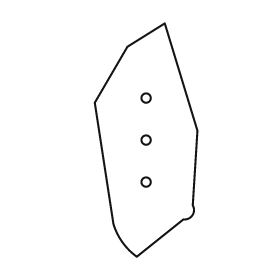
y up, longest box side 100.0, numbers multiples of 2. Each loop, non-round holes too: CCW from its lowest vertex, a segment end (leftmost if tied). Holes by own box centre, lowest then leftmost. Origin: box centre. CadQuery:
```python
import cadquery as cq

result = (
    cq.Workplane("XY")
    .moveTo(-4.0, -50.0)
    .lineTo(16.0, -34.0)
    .threePointArc((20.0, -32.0), (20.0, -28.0))
    .lineTo(22.0, 4.0)
    .lineTo(8.0, 50.0)
    .lineTo(-8.0, 40.0)
    .lineTo(-22.0, 16.0)
    .lineTo(-14.0, -36.0)
    .threePointArc((-10.0, -44.0), (-4.0, -50.0))
    .close()
    .moveTo(0.0, -18.0)
    .circle(2.0)
    .moveTo(0.0, 0.0)
    .circle(2.0)
    .moveTo(0.0, 18.0)
    .circle(2.0)
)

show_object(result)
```